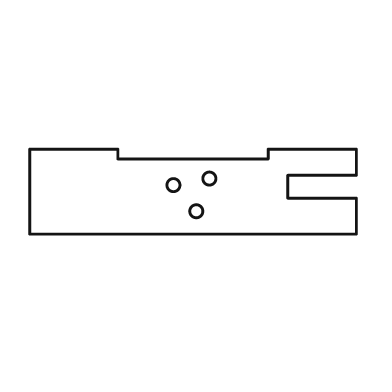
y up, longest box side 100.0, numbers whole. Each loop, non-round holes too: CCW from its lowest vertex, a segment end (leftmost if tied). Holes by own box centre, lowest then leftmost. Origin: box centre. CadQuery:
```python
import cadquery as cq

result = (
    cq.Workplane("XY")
    .moveTo(-50.0, -13.0)
    .lineTo(50.0, -13.0)
    .lineTo(50.0, -2.0)
    .lineTo(29.0, -2.0)
    .lineTo(29.0, 5.0)
    .lineTo(50.0, 5.0)
    .lineTo(50.0, 13.0)
    .lineTo(23.0, 13.0)
    .lineTo(23.0, 10.0)
    .lineTo(-23.0, 10.0)
    .lineTo(-23.0, 13.0)
    .lineTo(-50.0, 13.0)
    .close()
    .moveTo(1.0, -6.0)
    .circle(2.0)
    .moveTo(-6.0, 2.0)
    .circle(2.0)
    .moveTo(5.0, 4.0)
    .circle(2.0)
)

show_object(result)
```